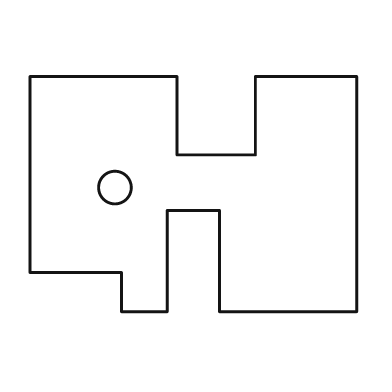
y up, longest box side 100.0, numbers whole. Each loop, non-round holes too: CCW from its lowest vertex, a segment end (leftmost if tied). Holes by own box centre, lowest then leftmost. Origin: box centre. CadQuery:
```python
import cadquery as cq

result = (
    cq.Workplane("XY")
    .moveTo(-22.0, -36.0)
    .lineTo(-8.0, -36.0)
    .lineTo(-8.0, -5.0)
    .lineTo(8.0, -5.0)
    .lineTo(8.0, -36.0)
    .lineTo(50.0, -36.0)
    .lineTo(50.0, 36.0)
    .lineTo(19.0, 36.0)
    .lineTo(19.0, 12.0)
    .lineTo(-5.0, 12.0)
    .lineTo(-5.0, 36.0)
    .lineTo(-50.0, 36.0)
    .lineTo(-50.0, -24.0)
    .lineTo(-22.0, -24.0)
    .close()
    .moveTo(-24.0, 2.0)
    .circle(5.0)
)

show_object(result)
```